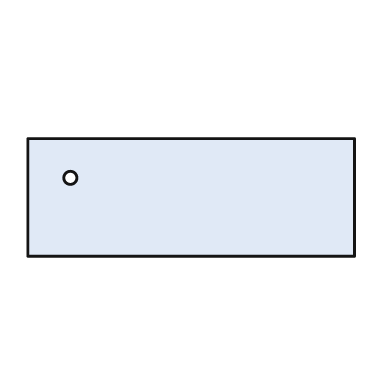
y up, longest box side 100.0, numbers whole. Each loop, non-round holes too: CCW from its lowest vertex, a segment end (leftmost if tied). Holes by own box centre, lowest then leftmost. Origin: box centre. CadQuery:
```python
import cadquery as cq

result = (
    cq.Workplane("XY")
    .moveTo(-50.0, -18.0)
    .lineTo(50.0, -18.0)
    .lineTo(50.0, 18.0)
    .lineTo(-50.0, 18.0)
    .close()
    .moveTo(-37.0, 6.0)
    .circle(2.0)
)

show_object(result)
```